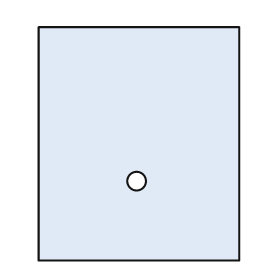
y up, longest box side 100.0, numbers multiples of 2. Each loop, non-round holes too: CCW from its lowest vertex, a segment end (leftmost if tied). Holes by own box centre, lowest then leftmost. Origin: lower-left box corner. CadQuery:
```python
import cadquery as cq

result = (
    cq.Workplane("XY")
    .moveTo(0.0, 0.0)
    .lineTo(86.0, 0.0)
    .lineTo(86.0, 100.0)
    .lineTo(0.0, 100.0)
    .close()
    .moveTo(42.0, 34.0)
    .circle(4.0)
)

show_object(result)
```